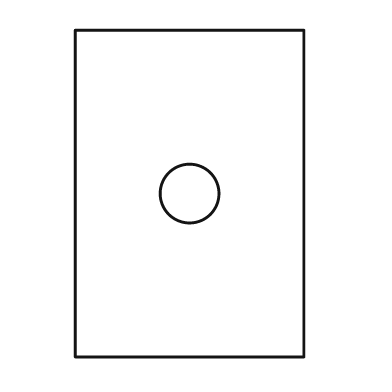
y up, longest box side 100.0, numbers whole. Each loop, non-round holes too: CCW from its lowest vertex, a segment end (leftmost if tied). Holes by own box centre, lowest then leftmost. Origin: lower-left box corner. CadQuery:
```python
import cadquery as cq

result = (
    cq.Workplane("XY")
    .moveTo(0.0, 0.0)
    .lineTo(70.0, 0.0)
    .lineTo(70.0, 100.0)
    .lineTo(0.0, 100.0)
    .close()
    .moveTo(35.0, 50.0)
    .circle(9.0)
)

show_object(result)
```